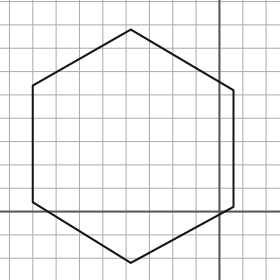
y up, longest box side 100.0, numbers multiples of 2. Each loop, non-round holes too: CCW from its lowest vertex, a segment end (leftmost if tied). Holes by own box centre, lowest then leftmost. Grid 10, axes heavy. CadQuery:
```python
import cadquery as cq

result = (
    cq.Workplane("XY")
    .moveTo(-38.0, -22.0)
    .lineTo(6.0, 2.0)
    .lineTo(6.0, 52.0)
    .lineTo(-38.0, 78.0)
    .lineTo(-80.0, 54.0)
    .lineTo(-80.0, 4.0)
    .close()
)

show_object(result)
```